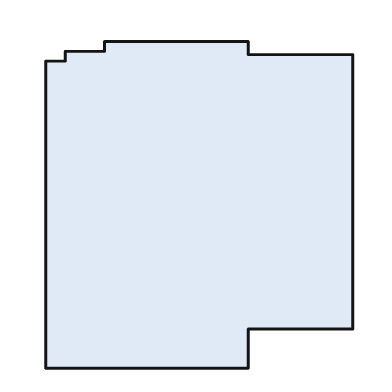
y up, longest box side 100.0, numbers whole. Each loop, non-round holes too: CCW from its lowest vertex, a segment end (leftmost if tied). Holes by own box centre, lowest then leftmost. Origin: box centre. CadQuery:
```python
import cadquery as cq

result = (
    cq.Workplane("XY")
    .moveTo(-47.0, -50.0)
    .lineTo(15.0, -50.0)
    .lineTo(15.0, -38.0)
    .lineTo(47.0, -38.0)
    .lineTo(47.0, 46.0)
    .lineTo(15.0, 46.0)
    .lineTo(15.0, 50.0)
    .lineTo(-29.0, 50.0)
    .lineTo(-29.0, 47.0)
    .lineTo(-41.0, 47.0)
    .lineTo(-41.0, 44.0)
    .lineTo(-47.0, 44.0)
    .close()
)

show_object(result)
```